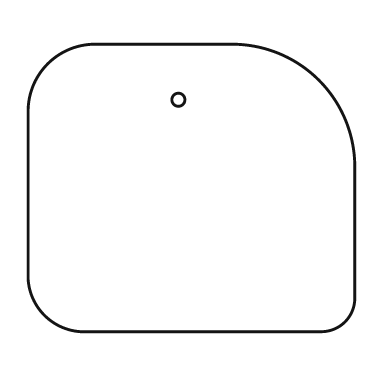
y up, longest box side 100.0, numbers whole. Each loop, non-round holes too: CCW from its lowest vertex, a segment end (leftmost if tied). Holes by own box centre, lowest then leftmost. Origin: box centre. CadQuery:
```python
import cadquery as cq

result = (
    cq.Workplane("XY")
    .moveTo(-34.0, -44.0)
    .lineTo(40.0, -44.0)
    .threePointArc((47.0, -41.0), (50.0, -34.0))
    .lineTo(50.0, 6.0)
    .threePointArc((39.0, 33.0), (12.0, 44.0))
    .lineTo(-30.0, 44.0)
    .threePointArc((-44.0, 38.0), (-50.0, 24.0))
    .lineTo(-50.0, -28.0)
    .threePointArc((-45.0, -39.0), (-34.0, -44.0))
    .close()
    .moveTo(-4.0, 27.0)
    .circle(2.0)
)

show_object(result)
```